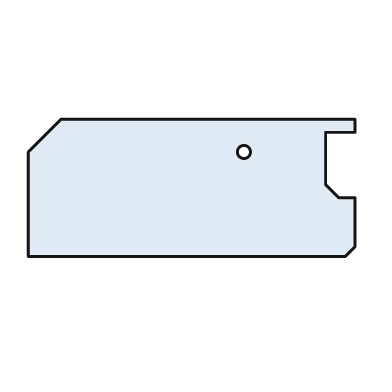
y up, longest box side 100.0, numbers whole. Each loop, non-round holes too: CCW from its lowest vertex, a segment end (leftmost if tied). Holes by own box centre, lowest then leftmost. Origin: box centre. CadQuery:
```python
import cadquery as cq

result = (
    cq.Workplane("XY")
    .moveTo(-50.0, -21.0)
    .lineTo(47.0, -21.0)
    .lineTo(50.0, -18.0)
    .lineTo(50.0, -3.0)
    .lineTo(45.0, -3.0)
    .lineTo(41.0, 1.0)
    .lineTo(41.0, 17.0)
    .lineTo(50.0, 17.0)
    .lineTo(50.0, 21.0)
    .lineTo(-40.0, 21.0)
    .lineTo(-50.0, 11.0)
    .close()
    .moveTo(16.0, 11.0)
    .circle(2.0)
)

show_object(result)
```